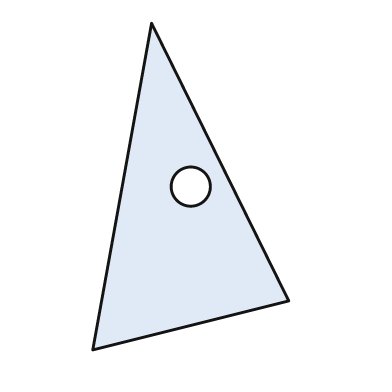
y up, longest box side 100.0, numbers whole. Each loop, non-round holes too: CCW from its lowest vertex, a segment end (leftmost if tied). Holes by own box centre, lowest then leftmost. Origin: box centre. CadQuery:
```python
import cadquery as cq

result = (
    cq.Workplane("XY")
    .moveTo(-30.0, -50.0)
    .lineTo(30.0, -35.0)
    .lineTo(-12.0, 50.0)
    .close()
    .moveTo(0.0, 0.0)
    .circle(6.0)
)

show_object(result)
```